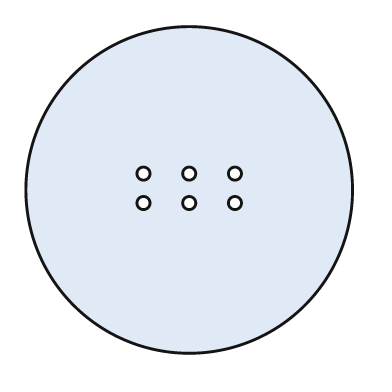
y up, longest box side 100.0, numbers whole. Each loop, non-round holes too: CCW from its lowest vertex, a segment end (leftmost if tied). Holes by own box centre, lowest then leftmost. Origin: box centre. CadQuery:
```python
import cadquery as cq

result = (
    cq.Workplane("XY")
    .moveTo(0.0, 0.0)
    .circle(50.0)
    .moveTo(-14.0, -4.0)
    .circle(2.0)
    .moveTo(0.0, -4.0)
    .circle(2.0)
    .moveTo(14.0, -4.0)
    .circle(2.0)
    .moveTo(-14.0, 5.0)
    .circle(2.0)
    .moveTo(0.0, 5.0)
    .circle(2.0)
    .moveTo(14.0, 5.0)
    .circle(2.0)
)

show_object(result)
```